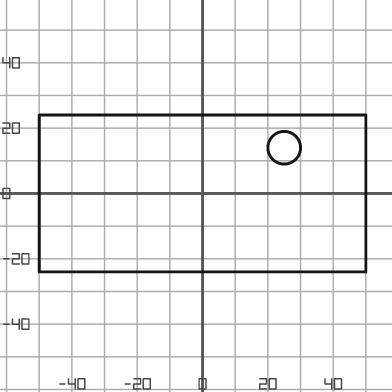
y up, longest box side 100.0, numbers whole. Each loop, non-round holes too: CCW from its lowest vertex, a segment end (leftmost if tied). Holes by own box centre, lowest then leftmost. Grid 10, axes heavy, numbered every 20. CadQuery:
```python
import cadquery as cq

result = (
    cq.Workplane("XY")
    .moveTo(-50.0, -24.0)
    .lineTo(50.0, -24.0)
    .lineTo(50.0, 24.0)
    .lineTo(-50.0, 24.0)
    .close()
    .moveTo(25.0, 14.0)
    .circle(5.0)
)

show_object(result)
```